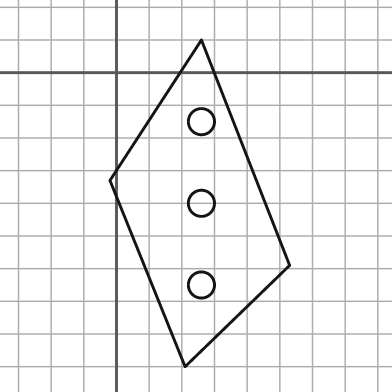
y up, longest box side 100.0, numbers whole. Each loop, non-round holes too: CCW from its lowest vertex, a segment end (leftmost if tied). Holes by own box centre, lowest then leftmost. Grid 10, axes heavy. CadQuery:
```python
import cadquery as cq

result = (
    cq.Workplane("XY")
    .moveTo(21.0, -90.0)
    .lineTo(53.0, -59.0)
    .lineTo(26.0, 10.0)
    .lineTo(-2.0, -33.0)
    .close()
    .moveTo(26.0, -65.0)
    .circle(4.0)
    .moveTo(26.0, -40.0)
    .circle(4.0)
    .moveTo(26.0, -15.0)
    .circle(4.0)
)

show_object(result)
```